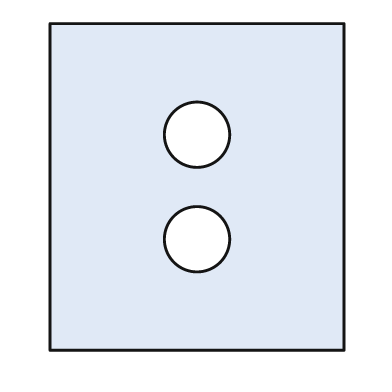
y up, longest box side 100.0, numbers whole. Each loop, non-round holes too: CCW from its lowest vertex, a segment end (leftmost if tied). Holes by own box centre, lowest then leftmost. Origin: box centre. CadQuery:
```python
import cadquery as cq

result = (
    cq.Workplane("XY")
    .moveTo(-45.0, -50.0)
    .lineTo(45.0, -50.0)
    .lineTo(45.0, 50.0)
    .lineTo(-45.0, 50.0)
    .close()
    .moveTo(0.0, -16.0)
    .circle(10.0)
    .moveTo(0.0, 16.0)
    .circle(10.0)
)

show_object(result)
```